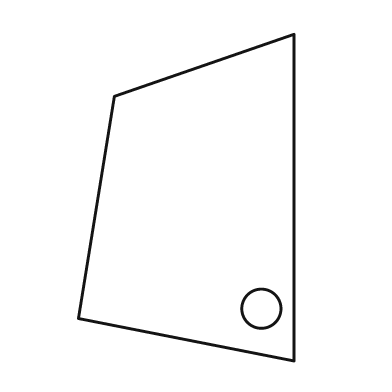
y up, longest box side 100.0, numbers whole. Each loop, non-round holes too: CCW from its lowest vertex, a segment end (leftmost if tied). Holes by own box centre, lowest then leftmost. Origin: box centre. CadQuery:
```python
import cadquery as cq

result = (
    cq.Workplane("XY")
    .moveTo(33.0, -50.0)
    .lineTo(33.0, 50.0)
    .lineTo(-22.0, 31.0)
    .lineTo(-33.0, -37.0)
    .close()
    .moveTo(23.0, -34.0)
    .circle(6.0)
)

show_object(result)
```